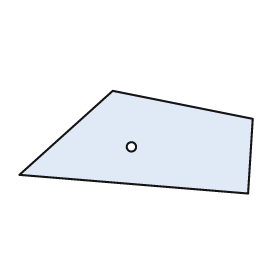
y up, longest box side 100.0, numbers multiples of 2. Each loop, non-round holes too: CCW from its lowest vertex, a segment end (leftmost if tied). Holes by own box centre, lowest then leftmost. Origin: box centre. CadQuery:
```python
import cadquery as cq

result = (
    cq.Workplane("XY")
    .moveTo(48.0, -22.0)
    .lineTo(50.0, 10.0)
    .lineTo(-10.0, 22.0)
    .lineTo(-50.0, -14.0)
    .close()
    .moveTo(-2.0, -2.0)
    .circle(2.0)
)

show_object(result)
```